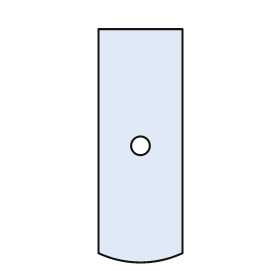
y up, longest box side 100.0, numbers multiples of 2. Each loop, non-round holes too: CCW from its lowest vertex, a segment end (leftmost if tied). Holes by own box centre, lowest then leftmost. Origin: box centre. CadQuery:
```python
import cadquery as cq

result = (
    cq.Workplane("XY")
    .moveTo(-18.0, -46.0)
    .threePointArc((0.0, -50.0), (18.0, -46.0))
    .lineTo(18.0, 50.0)
    .lineTo(-18.0, 50.0)
    .close()
    .moveTo(0.0, 0.0)
    .circle(4.0)
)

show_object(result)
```